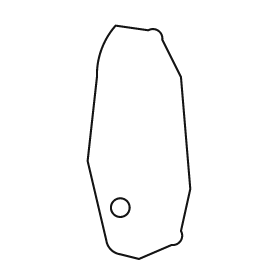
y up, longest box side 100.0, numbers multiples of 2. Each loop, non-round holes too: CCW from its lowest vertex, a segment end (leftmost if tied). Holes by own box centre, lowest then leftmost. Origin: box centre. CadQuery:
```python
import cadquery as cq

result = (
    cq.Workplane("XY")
    .moveTo(0.0, -50.0)
    .lineTo(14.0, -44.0)
    .threePointArc((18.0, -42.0), (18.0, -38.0))
    .lineTo(22.0, -20.0)
    .lineTo(18.0, 28.0)
    .lineTo(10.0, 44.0)
    .threePointArc((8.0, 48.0), (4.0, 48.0))
    .lineTo(-10.0, 50.0)
    .threePointArc((-16.0, 40.0), (-18.0, 28.0))
    .lineTo(-22.0, -8.0)
    .lineTo(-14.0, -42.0)
    .threePointArc((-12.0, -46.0), (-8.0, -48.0))
    .close()
    .moveTo(-8.0, -28.0)
    .circle(4.0)
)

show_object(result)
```